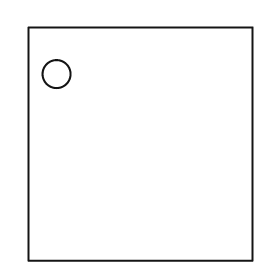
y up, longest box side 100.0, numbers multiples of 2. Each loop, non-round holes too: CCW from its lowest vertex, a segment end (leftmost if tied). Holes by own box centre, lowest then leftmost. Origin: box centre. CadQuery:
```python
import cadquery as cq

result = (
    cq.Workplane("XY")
    .moveTo(-48.0, -50.0)
    .lineTo(48.0, -50.0)
    .lineTo(48.0, 50.0)
    .lineTo(-48.0, 50.0)
    .close()
    .moveTo(-36.0, 30.0)
    .circle(6.0)
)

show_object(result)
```